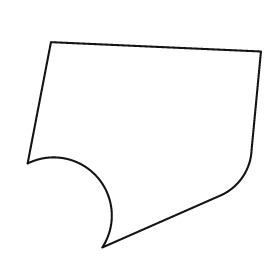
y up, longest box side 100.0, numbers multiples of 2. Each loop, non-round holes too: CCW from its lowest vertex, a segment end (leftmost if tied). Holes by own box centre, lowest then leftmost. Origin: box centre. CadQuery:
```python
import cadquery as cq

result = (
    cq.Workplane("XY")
    .moveTo(-18.0, -44.0)
    .lineTo(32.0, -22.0)
    .threePointArc((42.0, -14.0), (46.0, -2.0))
    .lineTo(50.0, 40.0)
    .lineTo(-40.0, 44.0)
    .lineTo(-50.0, -8.0)
    .threePointArc((-20.0, -14.0), (-18.0, -44.0))
    .close()
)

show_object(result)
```